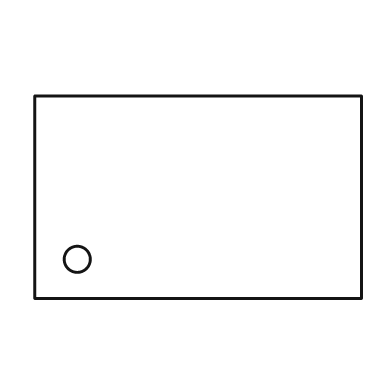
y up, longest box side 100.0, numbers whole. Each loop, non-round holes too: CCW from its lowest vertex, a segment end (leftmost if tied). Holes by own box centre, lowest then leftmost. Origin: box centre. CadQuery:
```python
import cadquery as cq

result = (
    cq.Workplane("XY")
    .moveTo(-50.0, -31.0)
    .lineTo(50.0, -31.0)
    .lineTo(50.0, 31.0)
    .lineTo(-50.0, 31.0)
    .close()
    .moveTo(-37.0, -19.0)
    .circle(4.0)
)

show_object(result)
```